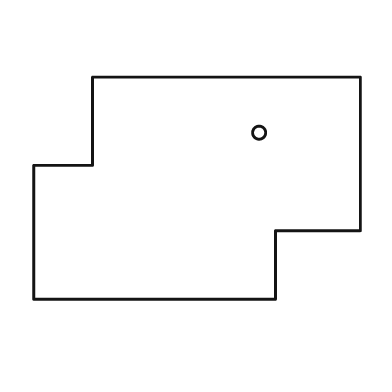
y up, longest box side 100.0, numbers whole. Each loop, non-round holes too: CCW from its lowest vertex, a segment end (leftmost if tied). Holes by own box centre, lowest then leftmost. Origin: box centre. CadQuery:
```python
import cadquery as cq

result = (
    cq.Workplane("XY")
    .moveTo(-50.0, -34.0)
    .lineTo(24.0, -34.0)
    .lineTo(24.0, -13.0)
    .lineTo(50.0, -13.0)
    .lineTo(50.0, 34.0)
    .lineTo(-32.0, 34.0)
    .lineTo(-32.0, 7.0)
    .lineTo(-50.0, 7.0)
    .close()
    .moveTo(19.0, 17.0)
    .circle(2.0)
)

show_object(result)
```